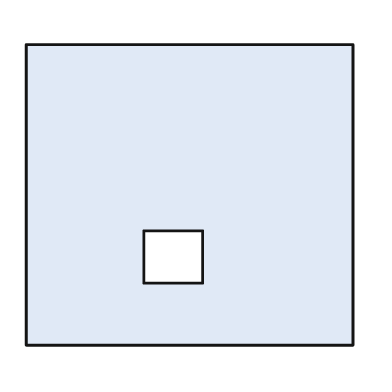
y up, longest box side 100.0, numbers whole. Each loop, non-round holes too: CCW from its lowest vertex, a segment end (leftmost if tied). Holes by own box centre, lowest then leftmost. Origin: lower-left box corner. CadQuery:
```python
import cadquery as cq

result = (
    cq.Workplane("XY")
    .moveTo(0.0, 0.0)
    .lineTo(100.0, 0.0)
    .lineTo(100.0, 92.0)
    .lineTo(0.0, 92.0)
    .close()
    .moveTo(36.0, 19.0)
    .lineTo(54.0, 19.0)
    .lineTo(54.0, 35.0)
    .lineTo(36.0, 35.0)
    .close()
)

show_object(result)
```